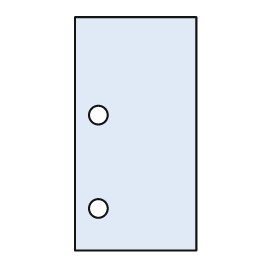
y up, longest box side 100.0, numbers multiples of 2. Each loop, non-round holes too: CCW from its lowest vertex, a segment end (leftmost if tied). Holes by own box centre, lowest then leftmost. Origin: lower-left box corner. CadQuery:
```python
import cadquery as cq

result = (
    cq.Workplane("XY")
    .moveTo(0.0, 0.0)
    .lineTo(52.0, 0.0)
    .lineTo(52.0, 100.0)
    .lineTo(0.0, 100.0)
    .close()
    .moveTo(10.0, 18.0)
    .circle(4.0)
    .moveTo(10.0, 58.0)
    .circle(4.0)
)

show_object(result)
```